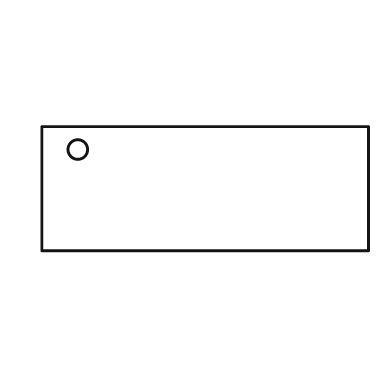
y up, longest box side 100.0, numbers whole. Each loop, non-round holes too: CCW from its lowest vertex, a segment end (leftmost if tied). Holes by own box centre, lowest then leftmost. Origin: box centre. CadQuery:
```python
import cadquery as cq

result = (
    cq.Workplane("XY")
    .moveTo(-50.0, -19.0)
    .lineTo(50.0, -19.0)
    .lineTo(50.0, 19.0)
    .lineTo(-50.0, 19.0)
    .close()
    .moveTo(-39.0, 12.0)
    .circle(3.0)
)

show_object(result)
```